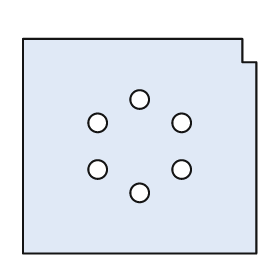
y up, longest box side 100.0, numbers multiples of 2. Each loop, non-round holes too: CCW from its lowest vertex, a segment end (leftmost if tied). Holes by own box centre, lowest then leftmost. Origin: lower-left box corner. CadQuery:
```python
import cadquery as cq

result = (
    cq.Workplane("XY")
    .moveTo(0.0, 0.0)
    .lineTo(100.0, 0.0)
    .lineTo(100.0, 82.0)
    .lineTo(94.0, 82.0)
    .lineTo(94.0, 92.0)
    .lineTo(0.0, 92.0)
    .close()
    .moveTo(50.0, 26.0)
    .circle(4.0)
    .moveTo(32.0, 36.0)
    .circle(4.0)
    .moveTo(68.0, 36.0)
    .circle(4.0)
    .moveTo(32.0, 56.0)
    .circle(4.0)
    .moveTo(68.0, 56.0)
    .circle(4.0)
    .moveTo(50.0, 66.0)
    .circle(4.0)
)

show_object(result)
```